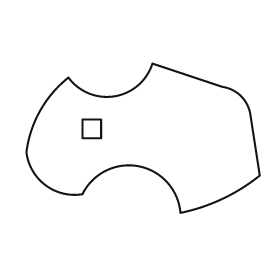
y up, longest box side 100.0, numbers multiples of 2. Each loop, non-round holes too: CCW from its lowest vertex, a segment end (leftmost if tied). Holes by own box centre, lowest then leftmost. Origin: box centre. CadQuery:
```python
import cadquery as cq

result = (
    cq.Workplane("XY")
    .moveTo(16.0, -32.0)
    .threePointArc((34.0, -26.0), (50.0, -16.0))
    .lineTo(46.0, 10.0)
    .threePointArc((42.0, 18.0), (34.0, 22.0))
    .lineTo(4.0, 32.0)
    .threePointArc((-12.0, 18.0), (-32.0, 26.0))
    .threePointArc((-44.0, 12.0), (-50.0, -6.0))
    .threePointArc((-42.0, -20.0), (-26.0, -24.0))
    .threePointArc((-2.0, -12.0), (16.0, -32.0))
    .close()
    .moveTo(-26.0, 0.0)
    .lineTo(-18.0, 0.0)
    .lineTo(-18.0, 8.0)
    .lineTo(-26.0, 8.0)
    .close()
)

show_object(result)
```